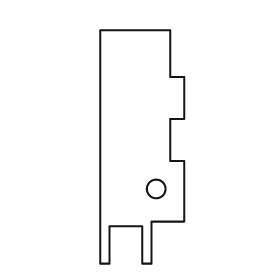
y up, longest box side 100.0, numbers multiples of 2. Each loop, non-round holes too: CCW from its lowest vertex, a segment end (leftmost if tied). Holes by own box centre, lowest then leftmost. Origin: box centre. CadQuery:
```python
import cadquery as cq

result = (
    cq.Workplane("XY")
    .moveTo(-18.0, -50.0)
    .lineTo(-14.0, -50.0)
    .lineTo(-14.0, -34.0)
    .lineTo(0.0, -34.0)
    .lineTo(0.0, -50.0)
    .lineTo(4.0, -50.0)
    .lineTo(4.0, -32.0)
    .lineTo(18.0, -32.0)
    .lineTo(18.0, -6.0)
    .lineTo(12.0, -6.0)
    .lineTo(12.0, 12.0)
    .lineTo(18.0, 12.0)
    .lineTo(18.0, 30.0)
    .lineTo(12.0, 30.0)
    .lineTo(12.0, 50.0)
    .lineTo(-18.0, 50.0)
    .close()
    .moveTo(6.0, -18.0)
    .circle(4.0)
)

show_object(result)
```